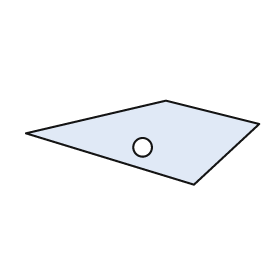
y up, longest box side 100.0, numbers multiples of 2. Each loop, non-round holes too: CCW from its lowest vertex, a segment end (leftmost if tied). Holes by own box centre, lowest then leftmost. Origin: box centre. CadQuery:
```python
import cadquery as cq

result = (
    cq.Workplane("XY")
    .moveTo(22.0, -18.0)
    .lineTo(50.0, 8.0)
    .lineTo(10.0, 18.0)
    .lineTo(-50.0, 4.0)
    .close()
    .moveTo(0.0, -2.0)
    .circle(4.0)
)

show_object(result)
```